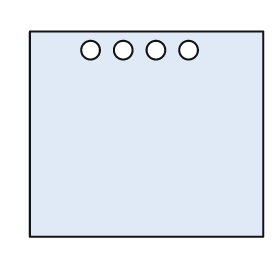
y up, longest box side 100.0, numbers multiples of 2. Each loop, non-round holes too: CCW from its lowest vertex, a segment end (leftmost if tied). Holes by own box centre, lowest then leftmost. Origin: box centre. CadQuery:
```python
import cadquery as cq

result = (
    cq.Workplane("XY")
    .moveTo(-50.0, -44.0)
    .lineTo(50.0, -44.0)
    .lineTo(50.0, 44.0)
    .lineTo(-50.0, 44.0)
    .close()
    .moveTo(-24.0, 36.0)
    .circle(4.0)
    .moveTo(-10.0, 36.0)
    .circle(4.0)
    .moveTo(4.0, 36.0)
    .circle(4.0)
    .moveTo(18.0, 36.0)
    .circle(4.0)
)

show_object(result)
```